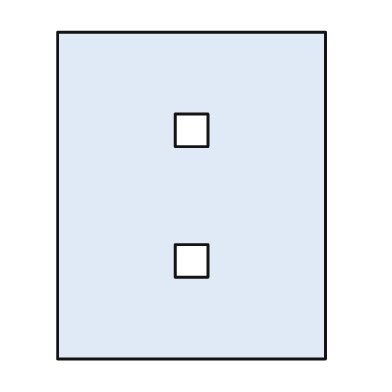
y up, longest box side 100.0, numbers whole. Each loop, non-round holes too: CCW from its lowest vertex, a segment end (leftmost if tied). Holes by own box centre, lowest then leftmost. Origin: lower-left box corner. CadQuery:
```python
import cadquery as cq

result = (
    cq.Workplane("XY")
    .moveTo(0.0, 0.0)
    .lineTo(82.0, 0.0)
    .lineTo(82.0, 100.0)
    .lineTo(0.0, 100.0)
    .close()
    .moveTo(36.0, 25.0)
    .lineTo(46.0, 25.0)
    .lineTo(46.0, 35.0)
    .lineTo(36.0, 35.0)
    .close()
    .moveTo(36.0, 65.0)
    .lineTo(46.0, 65.0)
    .lineTo(46.0, 75.0)
    .lineTo(36.0, 75.0)
    .close()
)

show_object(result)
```